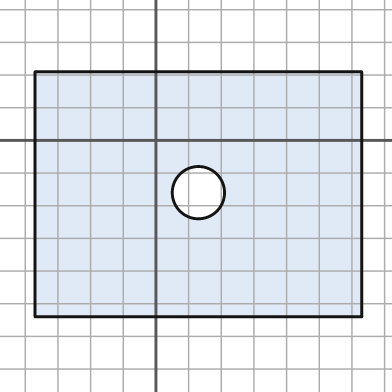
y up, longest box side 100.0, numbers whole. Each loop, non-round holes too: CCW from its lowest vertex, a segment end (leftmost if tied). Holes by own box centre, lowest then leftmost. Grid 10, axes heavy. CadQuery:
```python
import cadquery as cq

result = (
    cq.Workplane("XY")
    .moveTo(-37.0, -54.0)
    .lineTo(63.0, -54.0)
    .lineTo(63.0, 21.0)
    .lineTo(-37.0, 21.0)
    .close()
    .moveTo(13.0, -16.0)
    .circle(8.0)
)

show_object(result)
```